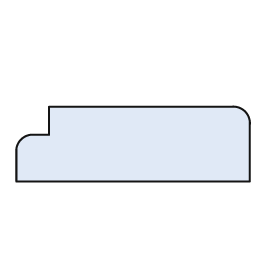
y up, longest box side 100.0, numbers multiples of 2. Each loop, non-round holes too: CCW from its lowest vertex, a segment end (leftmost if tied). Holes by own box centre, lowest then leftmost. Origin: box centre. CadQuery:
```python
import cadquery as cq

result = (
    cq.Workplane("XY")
    .moveTo(-50.0, -16.0)
    .lineTo(50.0, -16.0)
    .lineTo(50.0, 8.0)
    .threePointArc((48.0, 14.0), (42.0, 16.0))
    .lineTo(-36.0, 16.0)
    .lineTo(-36.0, 4.0)
    .lineTo(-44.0, 4.0)
    .threePointArc((-48.0, 2.0), (-50.0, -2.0))
    .close()
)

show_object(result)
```